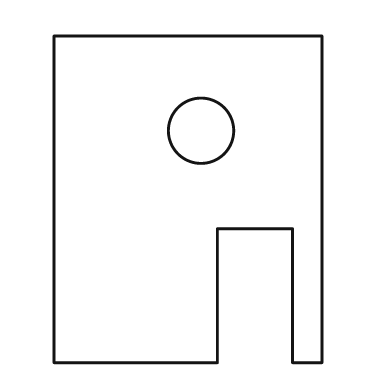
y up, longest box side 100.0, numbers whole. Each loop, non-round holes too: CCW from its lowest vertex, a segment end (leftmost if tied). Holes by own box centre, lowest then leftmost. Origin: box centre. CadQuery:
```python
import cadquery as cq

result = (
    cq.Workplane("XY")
    .moveTo(-41.0, -50.0)
    .lineTo(9.0, -50.0)
    .lineTo(9.0, -9.0)
    .lineTo(32.0, -9.0)
    .lineTo(32.0, -50.0)
    .lineTo(41.0, -50.0)
    .lineTo(41.0, 50.0)
    .lineTo(-41.0, 50.0)
    .close()
    .moveTo(4.0, 21.0)
    .circle(10.0)
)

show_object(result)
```